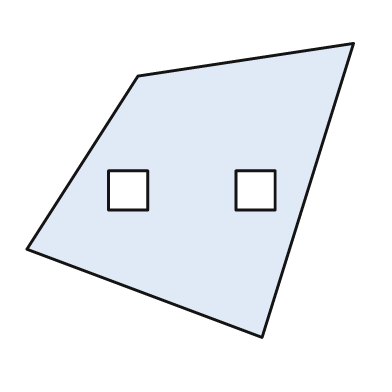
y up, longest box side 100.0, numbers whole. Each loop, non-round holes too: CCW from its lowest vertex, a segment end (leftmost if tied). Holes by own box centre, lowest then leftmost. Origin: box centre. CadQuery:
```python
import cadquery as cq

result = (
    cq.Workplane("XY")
    .moveTo(22.0, -45.0)
    .lineTo(50.0, 45.0)
    .lineTo(-16.0, 35.0)
    .lineTo(-50.0, -18.0)
    .close()
    .moveTo(-25.0, -6.0)
    .lineTo(-13.0, -6.0)
    .lineTo(-13.0, 6.0)
    .lineTo(-25.0, 6.0)
    .close()
    .moveTo(14.0, -6.0)
    .lineTo(26.0, -6.0)
    .lineTo(26.0, 6.0)
    .lineTo(14.0, 6.0)
    .close()
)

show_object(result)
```